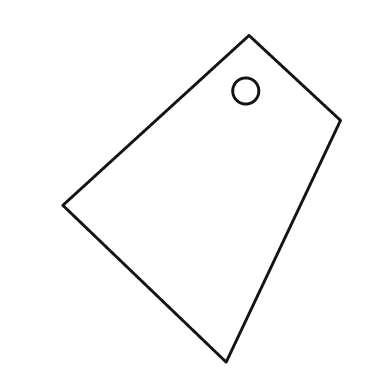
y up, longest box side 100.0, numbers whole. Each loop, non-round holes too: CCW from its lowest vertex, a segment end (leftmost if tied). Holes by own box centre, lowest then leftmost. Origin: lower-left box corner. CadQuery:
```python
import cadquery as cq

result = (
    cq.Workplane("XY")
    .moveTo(50.0, 0.0)
    .lineTo(85.0, 74.0)
    .lineTo(57.0, 100.0)
    .lineTo(0.0, 48.0)
    .close()
    .moveTo(56.0, 83.0)
    .circle(4.0)
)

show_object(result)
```